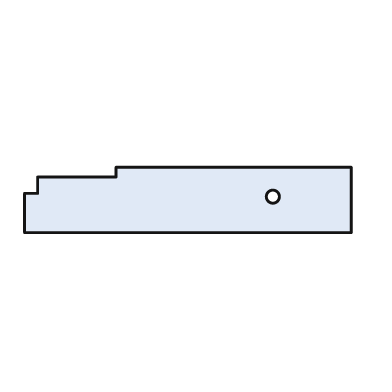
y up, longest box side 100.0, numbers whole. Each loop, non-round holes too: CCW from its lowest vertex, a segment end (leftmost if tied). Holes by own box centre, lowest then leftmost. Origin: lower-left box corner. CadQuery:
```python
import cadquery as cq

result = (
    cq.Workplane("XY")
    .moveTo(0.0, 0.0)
    .lineTo(100.0, 0.0)
    .lineTo(100.0, 20.0)
    .lineTo(28.0, 20.0)
    .lineTo(28.0, 17.0)
    .lineTo(4.0, 17.0)
    .lineTo(4.0, 12.0)
    .lineTo(0.0, 12.0)
    .close()
    .moveTo(76.0, 11.0)
    .circle(2.0)
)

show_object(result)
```